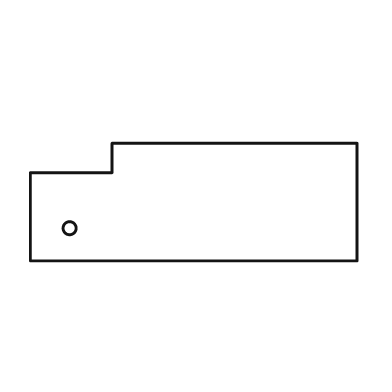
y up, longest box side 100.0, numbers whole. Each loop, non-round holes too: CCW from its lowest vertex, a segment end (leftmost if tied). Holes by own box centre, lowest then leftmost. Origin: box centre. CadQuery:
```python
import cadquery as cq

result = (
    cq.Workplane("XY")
    .moveTo(-50.0, -18.0)
    .lineTo(50.0, -18.0)
    .lineTo(50.0, 18.0)
    .lineTo(-25.0, 18.0)
    .lineTo(-25.0, 9.0)
    .lineTo(-50.0, 9.0)
    .close()
    .moveTo(-38.0, -8.0)
    .circle(2.0)
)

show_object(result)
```